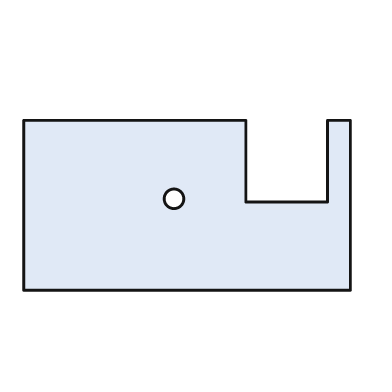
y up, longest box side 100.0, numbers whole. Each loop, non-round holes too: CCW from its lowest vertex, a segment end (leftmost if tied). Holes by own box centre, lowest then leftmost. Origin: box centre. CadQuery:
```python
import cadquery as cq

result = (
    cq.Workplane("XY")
    .moveTo(-50.0, -26.0)
    .lineTo(50.0, -26.0)
    .lineTo(50.0, 26.0)
    .lineTo(43.0, 26.0)
    .lineTo(43.0, 1.0)
    .lineTo(18.0, 1.0)
    .lineTo(18.0, 26.0)
    .lineTo(-50.0, 26.0)
    .close()
    .moveTo(-4.0, 2.0)
    .circle(3.0)
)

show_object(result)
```